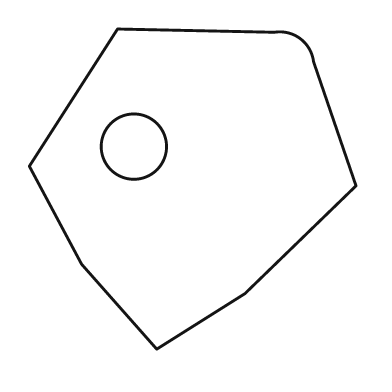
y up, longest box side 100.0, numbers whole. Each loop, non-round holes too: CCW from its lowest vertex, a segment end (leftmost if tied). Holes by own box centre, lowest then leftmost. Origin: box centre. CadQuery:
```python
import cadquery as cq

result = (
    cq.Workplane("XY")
    .moveTo(-11.0, -49.0)
    .lineTo(16.0, -32.0)
    .lineTo(50.0, 1.0)
    .lineTo(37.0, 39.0)
    .threePointArc((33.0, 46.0), (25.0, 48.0))
    .lineTo(-23.0, 49.0)
    .lineTo(-50.0, 7.0)
    .lineTo(-34.0, -23.0)
    .close()
    .moveTo(-18.0, 13.0)
    .circle(10.0)
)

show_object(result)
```